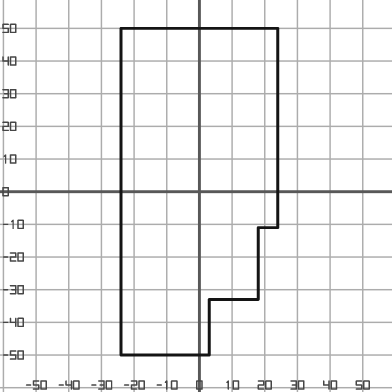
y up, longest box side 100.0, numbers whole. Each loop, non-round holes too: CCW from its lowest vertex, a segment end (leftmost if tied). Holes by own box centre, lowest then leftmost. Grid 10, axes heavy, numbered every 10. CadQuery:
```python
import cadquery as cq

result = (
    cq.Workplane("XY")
    .moveTo(-24.0, -50.0)
    .lineTo(3.0, -50.0)
    .lineTo(3.0, -33.0)
    .lineTo(18.0, -33.0)
    .lineTo(18.0, -11.0)
    .lineTo(24.0, -11.0)
    .lineTo(24.0, 50.0)
    .lineTo(-24.0, 50.0)
    .close()
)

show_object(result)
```